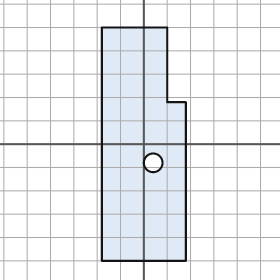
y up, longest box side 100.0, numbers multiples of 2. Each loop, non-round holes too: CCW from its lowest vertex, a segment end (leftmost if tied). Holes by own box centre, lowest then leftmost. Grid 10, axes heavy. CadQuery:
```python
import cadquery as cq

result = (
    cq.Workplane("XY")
    .moveTo(-18.0, -50.0)
    .lineTo(18.0, -50.0)
    .lineTo(18.0, 18.0)
    .lineTo(10.0, 18.0)
    .lineTo(10.0, 50.0)
    .lineTo(-18.0, 50.0)
    .close()
    .moveTo(4.0, -8.0)
    .circle(4.0)
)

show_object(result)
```